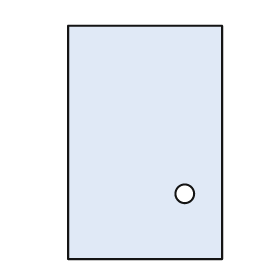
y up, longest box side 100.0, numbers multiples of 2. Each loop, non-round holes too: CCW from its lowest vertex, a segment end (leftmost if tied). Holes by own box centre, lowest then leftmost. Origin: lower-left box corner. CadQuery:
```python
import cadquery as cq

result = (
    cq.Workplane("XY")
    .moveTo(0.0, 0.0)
    .lineTo(66.0, 0.0)
    .lineTo(66.0, 100.0)
    .lineTo(0.0, 100.0)
    .close()
    .moveTo(50.0, 28.0)
    .circle(4.0)
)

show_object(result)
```